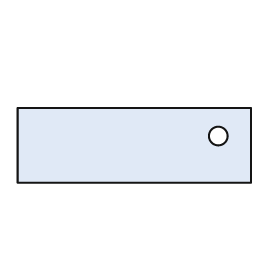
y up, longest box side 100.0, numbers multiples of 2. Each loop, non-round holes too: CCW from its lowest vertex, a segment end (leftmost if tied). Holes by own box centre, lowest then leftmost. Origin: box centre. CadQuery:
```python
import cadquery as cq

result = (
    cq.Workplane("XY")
    .moveTo(-50.0, -16.0)
    .lineTo(50.0, -16.0)
    .lineTo(50.0, 16.0)
    .lineTo(-50.0, 16.0)
    .close()
    .moveTo(36.0, 4.0)
    .circle(4.0)
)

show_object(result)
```